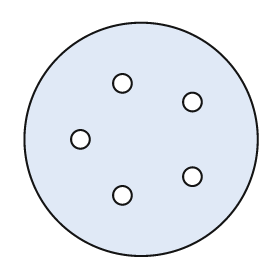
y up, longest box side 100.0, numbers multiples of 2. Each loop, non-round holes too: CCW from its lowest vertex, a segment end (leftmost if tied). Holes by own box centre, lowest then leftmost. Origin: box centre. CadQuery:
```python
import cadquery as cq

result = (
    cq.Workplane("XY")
    .moveTo(0.0, 0.0)
    .circle(50.0)
    .moveTo(-8.0, -24.0)
    .circle(4.0)
    .moveTo(22.0, -16.0)
    .circle(4.0)
    .moveTo(-26.0, 0.0)
    .circle(4.0)
    .moveTo(22.0, 16.0)
    .circle(4.0)
    .moveTo(-8.0, 24.0)
    .circle(4.0)
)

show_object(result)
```